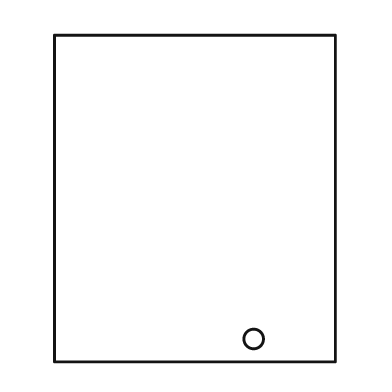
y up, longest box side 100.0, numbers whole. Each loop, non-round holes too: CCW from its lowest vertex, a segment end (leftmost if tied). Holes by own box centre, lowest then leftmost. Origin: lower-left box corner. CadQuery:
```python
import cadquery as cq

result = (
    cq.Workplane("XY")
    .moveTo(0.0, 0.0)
    .lineTo(86.0, 0.0)
    .lineTo(86.0, 100.0)
    .lineTo(0.0, 100.0)
    .close()
    .moveTo(61.0, 7.0)
    .circle(3.0)
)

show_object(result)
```